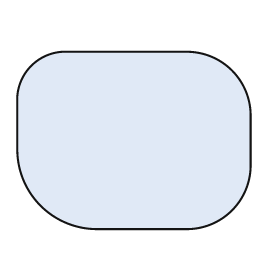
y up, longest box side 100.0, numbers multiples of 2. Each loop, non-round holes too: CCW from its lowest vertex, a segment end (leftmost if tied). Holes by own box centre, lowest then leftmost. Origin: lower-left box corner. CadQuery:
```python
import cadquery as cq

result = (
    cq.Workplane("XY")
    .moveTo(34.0, 0.0)
    .lineTo(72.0, 0.0)
    .threePointArc((92.0, 8.0), (100.0, 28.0))
    .lineTo(100.0, 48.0)
    .threePointArc((92.0, 68.0), (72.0, 76.0))
    .lineTo(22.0, 76.0)
    .threePointArc((6.0, 70.0), (0.0, 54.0))
    .lineTo(0.0, 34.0)
    .threePointArc((10.0, 10.0), (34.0, 0.0))
    .close()
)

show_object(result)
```